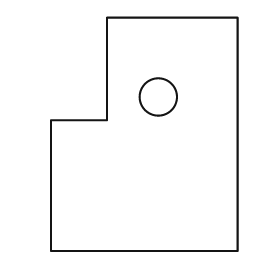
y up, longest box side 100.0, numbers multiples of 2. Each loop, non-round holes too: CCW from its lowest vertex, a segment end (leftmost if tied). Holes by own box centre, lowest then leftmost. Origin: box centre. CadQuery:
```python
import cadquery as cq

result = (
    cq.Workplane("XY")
    .moveTo(-40.0, -50.0)
    .lineTo(40.0, -50.0)
    .lineTo(40.0, 50.0)
    .lineTo(-16.0, 50.0)
    .lineTo(-16.0, 6.0)
    .lineTo(-40.0, 6.0)
    .close()
    .moveTo(6.0, 16.0)
    .circle(8.0)
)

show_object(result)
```